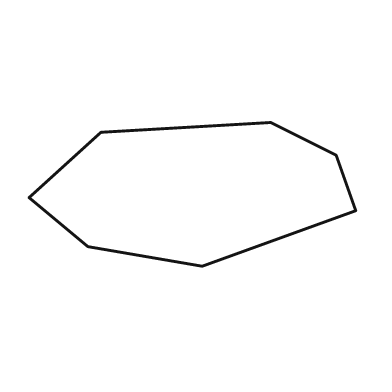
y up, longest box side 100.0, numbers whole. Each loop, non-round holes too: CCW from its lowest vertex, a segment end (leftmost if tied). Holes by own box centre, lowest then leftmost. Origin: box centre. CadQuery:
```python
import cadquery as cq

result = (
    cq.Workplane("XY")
    .moveTo(3.0, -22.0)
    .lineTo(50.0, -5.0)
    .lineTo(44.0, 12.0)
    .lineTo(24.0, 22.0)
    .lineTo(-28.0, 19.0)
    .lineTo(-50.0, -1.0)
    .lineTo(-32.0, -16.0)
    .close()
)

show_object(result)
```